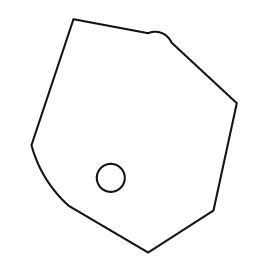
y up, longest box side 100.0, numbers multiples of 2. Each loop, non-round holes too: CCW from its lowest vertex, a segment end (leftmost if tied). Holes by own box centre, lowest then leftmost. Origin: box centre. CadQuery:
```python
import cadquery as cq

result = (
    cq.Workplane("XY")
    .moveTo(6.0, -50.0)
    .lineTo(34.0, -32.0)
    .lineTo(44.0, 14.0)
    .lineTo(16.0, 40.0)
    .threePointArc((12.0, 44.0), (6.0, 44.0))
    .lineTo(-26.0, 50.0)
    .lineTo(-44.0, -4.0)
    .threePointArc((-38.0, -18.0), (-28.0, -30.0))
    .close()
    .moveTo(-10.0, -18.0)
    .circle(6.0)
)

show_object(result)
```